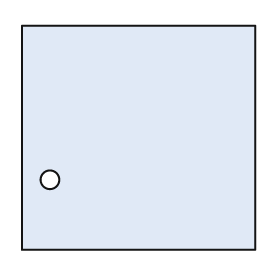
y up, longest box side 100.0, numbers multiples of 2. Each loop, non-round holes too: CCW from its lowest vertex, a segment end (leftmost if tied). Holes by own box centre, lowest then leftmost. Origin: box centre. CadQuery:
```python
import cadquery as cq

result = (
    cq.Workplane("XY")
    .moveTo(-50.0, -48.0)
    .lineTo(50.0, -48.0)
    .lineTo(50.0, 48.0)
    .lineTo(-50.0, 48.0)
    .close()
    .moveTo(-38.0, -18.0)
    .circle(4.0)
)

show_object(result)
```